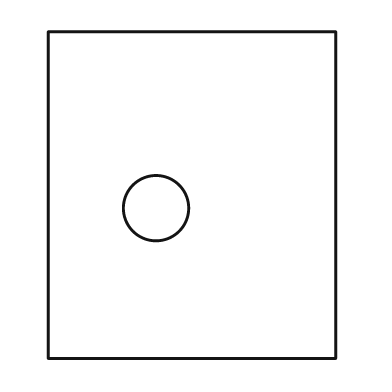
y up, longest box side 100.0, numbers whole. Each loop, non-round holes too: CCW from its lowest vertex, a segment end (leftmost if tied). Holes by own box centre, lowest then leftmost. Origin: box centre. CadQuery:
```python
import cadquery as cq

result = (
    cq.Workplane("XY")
    .moveTo(-44.0, -50.0)
    .lineTo(44.0, -50.0)
    .lineTo(44.0, 50.0)
    .lineTo(-44.0, 50.0)
    .close()
    .moveTo(-11.0, -4.0)
    .circle(10.0)
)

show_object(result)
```